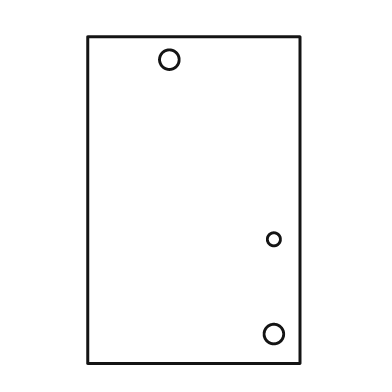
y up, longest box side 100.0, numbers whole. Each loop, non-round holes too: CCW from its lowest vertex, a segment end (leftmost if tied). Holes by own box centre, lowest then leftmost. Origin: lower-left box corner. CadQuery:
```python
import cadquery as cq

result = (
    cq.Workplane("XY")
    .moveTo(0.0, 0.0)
    .lineTo(65.0, 0.0)
    .lineTo(65.0, 100.0)
    .lineTo(0.0, 100.0)
    .close()
    .moveTo(57.0, 9.0)
    .circle(3.0)
    .moveTo(57.0, 38.0)
    .circle(2.0)
    .moveTo(25.0, 93.0)
    .circle(3.0)
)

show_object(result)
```